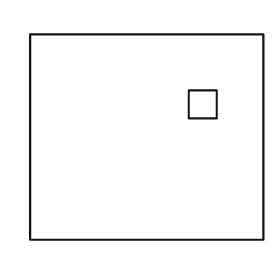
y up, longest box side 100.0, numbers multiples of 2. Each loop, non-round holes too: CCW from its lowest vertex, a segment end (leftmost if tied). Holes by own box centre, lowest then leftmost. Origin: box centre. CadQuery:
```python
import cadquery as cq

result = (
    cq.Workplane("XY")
    .moveTo(-50.0, -44.0)
    .lineTo(50.0, -44.0)
    .lineTo(50.0, 44.0)
    .lineTo(-50.0, 44.0)
    .close()
    .moveTo(18.0, 8.0)
    .lineTo(30.0, 8.0)
    .lineTo(30.0, 20.0)
    .lineTo(18.0, 20.0)
    .close()
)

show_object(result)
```